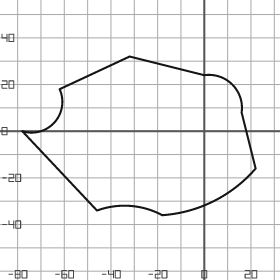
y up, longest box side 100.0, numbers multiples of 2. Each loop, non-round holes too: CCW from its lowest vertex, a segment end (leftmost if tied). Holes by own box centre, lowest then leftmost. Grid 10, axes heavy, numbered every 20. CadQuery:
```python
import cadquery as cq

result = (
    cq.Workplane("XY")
    .moveTo(-18.0, -36.0)
    .threePointArc((4.0, -30.0), (22.0, -16.0))
    .lineTo(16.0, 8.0)
    .threePointArc((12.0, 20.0), (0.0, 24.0))
    .lineTo(-32.0, 32.0)
    .lineTo(-62.0, 18.0)
    .threePointArc((-64.0, 4.0), (-78.0, 0.0))
    .lineTo(-46.0, -34.0)
    .threePointArc((-32.0, -32.0), (-18.0, -36.0))
    .close()
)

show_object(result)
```